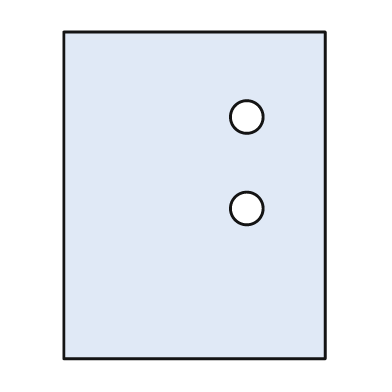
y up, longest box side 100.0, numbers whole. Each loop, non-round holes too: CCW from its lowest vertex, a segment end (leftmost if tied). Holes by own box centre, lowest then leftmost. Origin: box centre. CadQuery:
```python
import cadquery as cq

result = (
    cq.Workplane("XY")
    .moveTo(-40.0, -50.0)
    .lineTo(40.0, -50.0)
    .lineTo(40.0, 50.0)
    .lineTo(-40.0, 50.0)
    .close()
    .moveTo(16.0, -4.0)
    .circle(5.0)
    .moveTo(16.0, 24.0)
    .circle(5.0)
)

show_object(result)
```